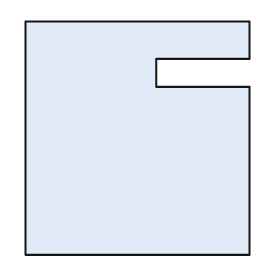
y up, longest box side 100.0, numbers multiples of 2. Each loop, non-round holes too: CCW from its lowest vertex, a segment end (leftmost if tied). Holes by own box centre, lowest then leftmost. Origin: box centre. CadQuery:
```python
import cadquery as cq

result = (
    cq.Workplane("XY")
    .moveTo(-48.0, -50.0)
    .lineTo(48.0, -50.0)
    .lineTo(48.0, 22.0)
    .lineTo(8.0, 22.0)
    .lineTo(8.0, 34.0)
    .lineTo(48.0, 34.0)
    .lineTo(48.0, 50.0)
    .lineTo(-48.0, 50.0)
    .close()
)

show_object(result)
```